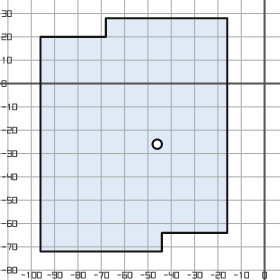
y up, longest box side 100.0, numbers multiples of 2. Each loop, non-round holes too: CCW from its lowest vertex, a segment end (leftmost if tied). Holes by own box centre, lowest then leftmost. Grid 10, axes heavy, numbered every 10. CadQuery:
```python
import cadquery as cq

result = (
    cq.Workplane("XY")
    .moveTo(-96.0, -72.0)
    .lineTo(-44.0, -72.0)
    .lineTo(-44.0, -64.0)
    .lineTo(-16.0, -64.0)
    .lineTo(-16.0, 28.0)
    .lineTo(-68.0, 28.0)
    .lineTo(-68.0, 20.0)
    .lineTo(-96.0, 20.0)
    .close()
    .moveTo(-46.0, -26.0)
    .circle(2.0)
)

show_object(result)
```